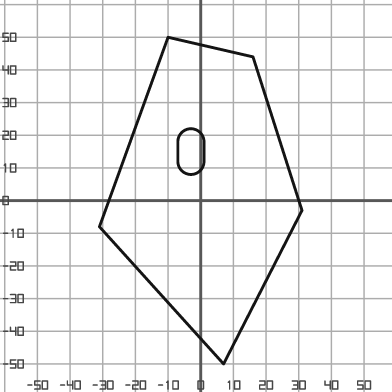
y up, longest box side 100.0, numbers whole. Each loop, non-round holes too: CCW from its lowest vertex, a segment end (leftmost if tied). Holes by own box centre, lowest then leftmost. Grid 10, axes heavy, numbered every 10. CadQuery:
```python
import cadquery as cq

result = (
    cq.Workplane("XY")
    .moveTo(7.0, -50.0)
    .lineTo(31.0, -3.0)
    .lineTo(16.0, 44.0)
    .lineTo(-10.0, 50.0)
    .lineTo(-31.0, -8.0)
    .close()
    .moveTo(-7.0, 12.0)
    .threePointArc((-3.0, 8.0), (1.0, 12.0))
    .lineTo(1.0, 18.0)
    .threePointArc((-3.0, 22.0), (-7.0, 18.0))
    .close()
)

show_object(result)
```